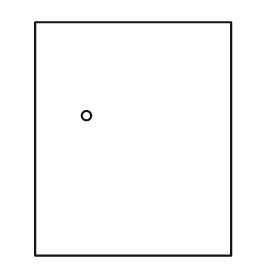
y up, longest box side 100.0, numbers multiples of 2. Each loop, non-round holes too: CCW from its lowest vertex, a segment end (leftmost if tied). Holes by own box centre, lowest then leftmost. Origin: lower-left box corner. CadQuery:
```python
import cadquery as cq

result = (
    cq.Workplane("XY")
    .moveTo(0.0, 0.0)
    .lineTo(84.0, 0.0)
    .lineTo(84.0, 100.0)
    .lineTo(0.0, 100.0)
    .close()
    .moveTo(22.0, 60.0)
    .circle(2.0)
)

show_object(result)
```